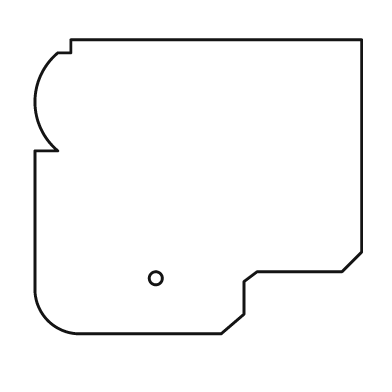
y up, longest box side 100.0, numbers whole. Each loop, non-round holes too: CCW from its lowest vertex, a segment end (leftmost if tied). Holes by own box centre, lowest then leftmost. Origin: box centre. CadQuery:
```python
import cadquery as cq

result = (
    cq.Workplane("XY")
    .moveTo(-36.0, -45.0)
    .lineTo(7.0, -45.0)
    .lineTo(14.0, -39.0)
    .lineTo(14.0, -29.0)
    .lineTo(18.0, -26.0)
    .lineTo(44.0, -26.0)
    .lineTo(50.0, -20.0)
    .lineTo(50.0, 45.0)
    .lineTo(-39.0, 45.0)
    .lineTo(-39.0, 41.0)
    .lineTo(-43.0, 41.0)
    .threePointArc((-50.0, 26.0), (-43.0, 11.0))
    .lineTo(-50.0, 11.0)
    .lineTo(-50.0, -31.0)
    .threePointArc((-46.0, -41.0), (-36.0, -45.0))
    .close()
    .moveTo(-13.0, -28.0)
    .circle(2.0)
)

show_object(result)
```